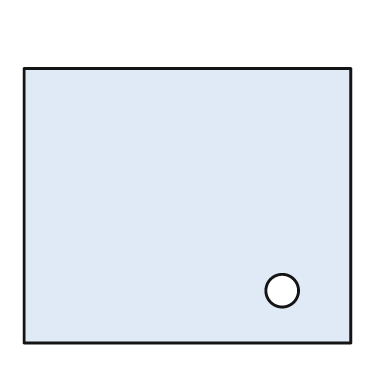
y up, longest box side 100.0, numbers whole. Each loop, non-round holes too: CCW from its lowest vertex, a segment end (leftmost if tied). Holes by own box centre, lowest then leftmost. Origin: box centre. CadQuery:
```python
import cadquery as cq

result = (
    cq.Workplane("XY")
    .moveTo(-50.0, -42.0)
    .lineTo(50.0, -42.0)
    .lineTo(50.0, 42.0)
    .lineTo(-50.0, 42.0)
    .close()
    .moveTo(29.0, -26.0)
    .circle(5.0)
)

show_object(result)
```